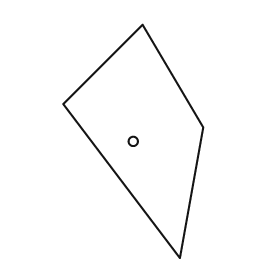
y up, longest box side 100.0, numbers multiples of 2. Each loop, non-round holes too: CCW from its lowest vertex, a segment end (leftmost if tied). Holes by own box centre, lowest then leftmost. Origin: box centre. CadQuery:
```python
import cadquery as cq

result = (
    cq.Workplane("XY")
    .moveTo(20.0, -50.0)
    .lineTo(30.0, 6.0)
    .lineTo(4.0, 50.0)
    .lineTo(-30.0, 16.0)
    .close()
    .moveTo(0.0, 0.0)
    .circle(2.0)
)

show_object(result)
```